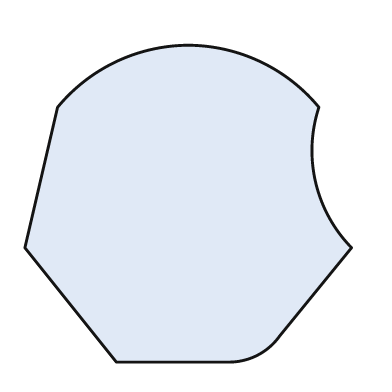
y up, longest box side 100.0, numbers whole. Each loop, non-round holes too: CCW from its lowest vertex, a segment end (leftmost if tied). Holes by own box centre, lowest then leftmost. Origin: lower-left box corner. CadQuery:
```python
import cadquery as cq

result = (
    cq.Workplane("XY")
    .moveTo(28.0, 0.0)
    .lineTo(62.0, 0.0)
    .threePointArc((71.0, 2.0), (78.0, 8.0))
    .lineTo(100.0, 35.0)
    .threePointArc((89.0, 55.0), (90.0, 78.0))
    .threePointArc((72.0, 92.0), (50.0, 97.0))
    .threePointArc((28.0, 92.0), (10.0, 78.0))
    .lineTo(0.0, 35.0)
    .close()
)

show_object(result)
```